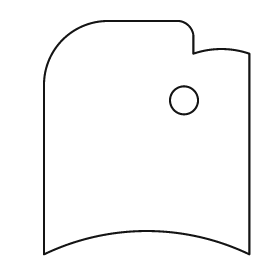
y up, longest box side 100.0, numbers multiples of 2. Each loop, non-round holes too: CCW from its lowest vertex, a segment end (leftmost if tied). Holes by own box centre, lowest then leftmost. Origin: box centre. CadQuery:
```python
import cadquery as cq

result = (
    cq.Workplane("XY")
    .moveTo(-44.0, -50.0)
    .threePointArc((0.0, -40.0), (44.0, -50.0))
    .lineTo(44.0, 36.0)
    .threePointArc((32.0, 38.0), (20.0, 36.0))
    .lineTo(20.0, 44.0)
    .threePointArc((18.0, 48.0), (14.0, 50.0))
    .lineTo(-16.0, 50.0)
    .threePointArc((-36.0, 42.0), (-44.0, 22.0))
    .close()
    .moveTo(16.0, 16.0)
    .circle(6.0)
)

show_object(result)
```